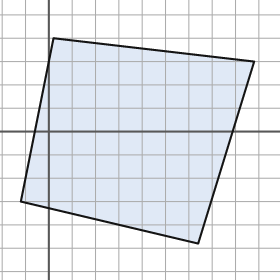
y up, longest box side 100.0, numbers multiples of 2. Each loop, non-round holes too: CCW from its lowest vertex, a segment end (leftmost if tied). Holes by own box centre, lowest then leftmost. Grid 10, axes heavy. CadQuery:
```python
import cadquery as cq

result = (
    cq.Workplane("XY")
    .moveTo(64.0, -48.0)
    .lineTo(88.0, 30.0)
    .lineTo(2.0, 40.0)
    .lineTo(-12.0, -30.0)
    .close()
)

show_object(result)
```